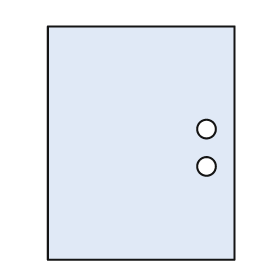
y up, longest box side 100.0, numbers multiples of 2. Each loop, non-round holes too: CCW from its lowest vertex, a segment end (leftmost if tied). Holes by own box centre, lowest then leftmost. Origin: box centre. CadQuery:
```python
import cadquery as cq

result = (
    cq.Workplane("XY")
    .moveTo(-40.0, -50.0)
    .lineTo(40.0, -50.0)
    .lineTo(40.0, 50.0)
    .lineTo(-40.0, 50.0)
    .close()
    .moveTo(28.0, -10.0)
    .circle(4.0)
    .moveTo(28.0, 6.0)
    .circle(4.0)
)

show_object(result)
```